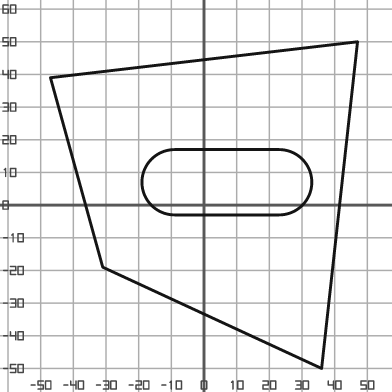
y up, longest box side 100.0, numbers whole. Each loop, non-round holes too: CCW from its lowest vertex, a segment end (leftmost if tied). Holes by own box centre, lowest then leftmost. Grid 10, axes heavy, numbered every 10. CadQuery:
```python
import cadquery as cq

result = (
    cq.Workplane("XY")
    .moveTo(36.0, -50.0)
    .lineTo(47.0, 50.0)
    .lineTo(-47.0, 39.0)
    .lineTo(-31.0, -19.0)
    .close()
    .moveTo(-9.0, -3.0)
    .lineTo(23.0, -3.0)
    .threePointArc((33.0, 7.0), (23.0, 17.0))
    .lineTo(-9.0, 17.0)
    .threePointArc((-19.0, 7.0), (-9.0, -3.0))
    .close()
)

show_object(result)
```